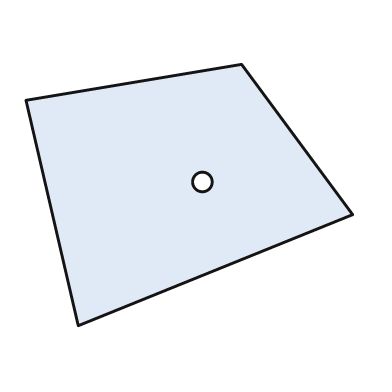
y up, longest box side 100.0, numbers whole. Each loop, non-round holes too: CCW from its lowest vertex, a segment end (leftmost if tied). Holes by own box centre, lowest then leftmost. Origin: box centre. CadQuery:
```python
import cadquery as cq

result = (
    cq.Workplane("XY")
    .moveTo(-34.0, -40.0)
    .lineTo(50.0, -6.0)
    .lineTo(16.0, 40.0)
    .lineTo(-50.0, 29.0)
    .close()
    .moveTo(4.0, 4.0)
    .circle(3.0)
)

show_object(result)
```